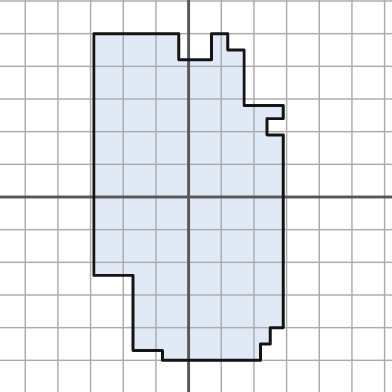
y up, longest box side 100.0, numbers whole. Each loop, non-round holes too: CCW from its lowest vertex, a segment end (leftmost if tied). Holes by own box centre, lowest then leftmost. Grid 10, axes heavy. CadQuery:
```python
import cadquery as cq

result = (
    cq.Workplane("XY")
    .moveTo(-8.0, -50.0)
    .lineTo(22.0, -50.0)
    .lineTo(22.0, -45.0)
    .lineTo(25.0, -45.0)
    .lineTo(25.0, -40.0)
    .lineTo(29.0, -40.0)
    .lineTo(29.0, 19.0)
    .lineTo(24.0, 19.0)
    .lineTo(24.0, 24.0)
    .lineTo(29.0, 24.0)
    .lineTo(29.0, 28.0)
    .lineTo(17.0, 28.0)
    .lineTo(17.0, 45.0)
    .lineTo(12.0, 45.0)
    .lineTo(12.0, 50.0)
    .lineTo(7.0, 50.0)
    .lineTo(7.0, 42.0)
    .lineTo(-3.0, 42.0)
    .lineTo(-3.0, 50.0)
    .lineTo(-29.0, 50.0)
    .lineTo(-29.0, -24.0)
    .lineTo(-17.0, -24.0)
    .lineTo(-17.0, -47.0)
    .lineTo(-8.0, -47.0)
    .close()
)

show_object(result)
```